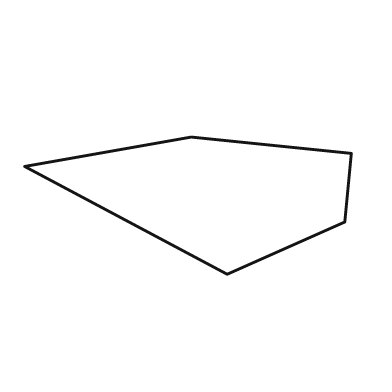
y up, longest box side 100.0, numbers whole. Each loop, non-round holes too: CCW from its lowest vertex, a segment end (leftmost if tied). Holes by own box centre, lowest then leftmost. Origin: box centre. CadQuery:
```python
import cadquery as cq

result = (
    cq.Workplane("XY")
    .moveTo(12.0, -21.0)
    .lineTo(48.0, -5.0)
    .lineTo(50.0, 16.0)
    .lineTo(1.0, 21.0)
    .lineTo(-50.0, 12.0)
    .close()
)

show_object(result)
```